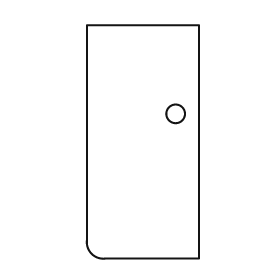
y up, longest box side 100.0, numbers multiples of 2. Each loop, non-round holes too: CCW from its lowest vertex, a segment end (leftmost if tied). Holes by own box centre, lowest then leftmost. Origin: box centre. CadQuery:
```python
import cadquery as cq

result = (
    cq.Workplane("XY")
    .moveTo(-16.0, -50.0)
    .lineTo(24.0, -50.0)
    .lineTo(24.0, 50.0)
    .lineTo(-24.0, 50.0)
    .lineTo(-24.0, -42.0)
    .threePointArc((-22.0, -48.0), (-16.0, -50.0))
    .close()
    .moveTo(14.0, 12.0)
    .circle(4.0)
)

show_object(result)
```